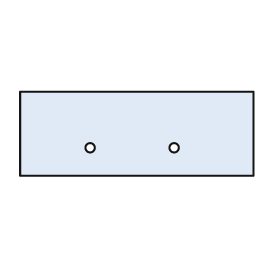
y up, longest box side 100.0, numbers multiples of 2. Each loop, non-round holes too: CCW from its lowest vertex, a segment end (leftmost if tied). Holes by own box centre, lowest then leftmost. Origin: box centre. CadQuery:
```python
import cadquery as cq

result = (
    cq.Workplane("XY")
    .moveTo(-50.0, -18.0)
    .lineTo(50.0, -18.0)
    .lineTo(50.0, 18.0)
    .lineTo(-50.0, 18.0)
    .close()
    .moveTo(-20.0, -6.0)
    .circle(2.0)
    .moveTo(16.0, -6.0)
    .circle(2.0)
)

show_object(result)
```